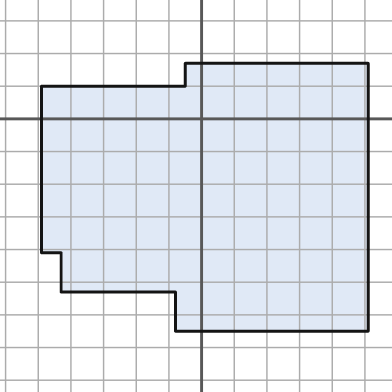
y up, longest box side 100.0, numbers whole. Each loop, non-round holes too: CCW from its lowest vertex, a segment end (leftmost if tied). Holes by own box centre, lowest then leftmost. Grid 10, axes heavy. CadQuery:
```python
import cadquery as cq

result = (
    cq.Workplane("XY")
    .moveTo(-8.0, -65.0)
    .lineTo(51.0, -65.0)
    .lineTo(51.0, 17.0)
    .lineTo(-5.0, 17.0)
    .lineTo(-5.0, 10.0)
    .lineTo(-49.0, 10.0)
    .lineTo(-49.0, -41.0)
    .lineTo(-43.0, -41.0)
    .lineTo(-43.0, -53.0)
    .lineTo(-8.0, -53.0)
    .close()
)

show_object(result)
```